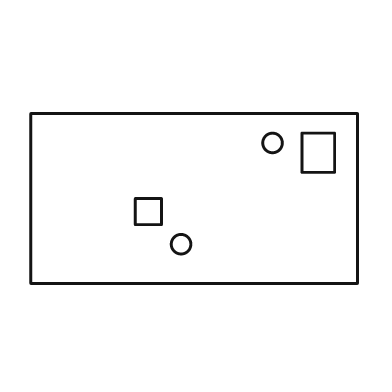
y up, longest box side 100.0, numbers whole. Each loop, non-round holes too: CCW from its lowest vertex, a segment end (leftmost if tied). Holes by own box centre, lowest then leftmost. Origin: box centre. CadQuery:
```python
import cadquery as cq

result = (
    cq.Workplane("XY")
    .moveTo(-50.0, -26.0)
    .lineTo(50.0, -26.0)
    .lineTo(50.0, 26.0)
    .lineTo(-50.0, 26.0)
    .close()
    .moveTo(-4.0, -14.0)
    .circle(3.0)
    .moveTo(-18.0, -8.0)
    .lineTo(-10.0, -8.0)
    .lineTo(-10.0, 0.0)
    .lineTo(-18.0, 0.0)
    .close()
    .moveTo(33.0, 8.0)
    .lineTo(43.0, 8.0)
    .lineTo(43.0, 20.0)
    .lineTo(33.0, 20.0)
    .close()
    .moveTo(24.0, 17.0)
    .circle(3.0)
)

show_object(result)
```